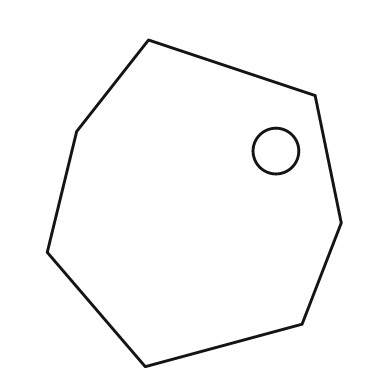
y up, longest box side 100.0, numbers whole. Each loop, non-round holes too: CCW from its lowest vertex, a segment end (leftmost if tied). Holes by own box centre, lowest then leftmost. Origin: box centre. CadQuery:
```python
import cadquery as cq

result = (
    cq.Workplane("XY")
    .moveTo(-15.0, -50.0)
    .lineTo(33.0, -37.0)
    .lineTo(45.0, -6.0)
    .lineTo(37.0, 33.0)
    .lineTo(-14.0, 50.0)
    .lineTo(-36.0, 22.0)
    .lineTo(-45.0, -15.0)
    .close()
    .moveTo(25.0, 16.0)
    .circle(7.0)
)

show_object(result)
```